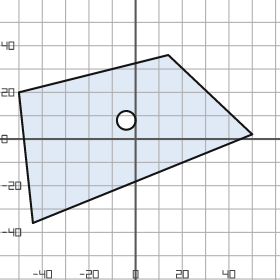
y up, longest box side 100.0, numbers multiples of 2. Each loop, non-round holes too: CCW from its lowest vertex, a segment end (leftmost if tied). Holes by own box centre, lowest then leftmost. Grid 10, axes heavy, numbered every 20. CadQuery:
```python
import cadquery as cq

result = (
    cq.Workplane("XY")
    .moveTo(-44.0, -36.0)
    .lineTo(50.0, 2.0)
    .lineTo(14.0, 36.0)
    .lineTo(-50.0, 20.0)
    .close()
    .moveTo(-4.0, 8.0)
    .circle(4.0)
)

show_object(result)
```